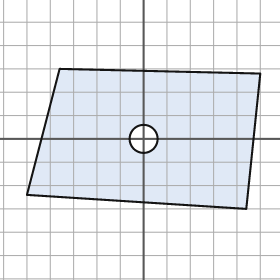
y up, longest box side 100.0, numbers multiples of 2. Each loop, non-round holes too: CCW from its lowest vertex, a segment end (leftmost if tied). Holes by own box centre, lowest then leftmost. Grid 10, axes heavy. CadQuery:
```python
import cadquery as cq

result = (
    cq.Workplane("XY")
    .moveTo(44.0, -30.0)
    .lineTo(50.0, 28.0)
    .lineTo(-36.0, 30.0)
    .lineTo(-50.0, -24.0)
    .close()
    .moveTo(0.0, 0.0)
    .circle(6.0)
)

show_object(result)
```